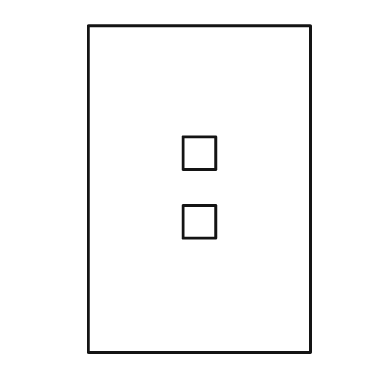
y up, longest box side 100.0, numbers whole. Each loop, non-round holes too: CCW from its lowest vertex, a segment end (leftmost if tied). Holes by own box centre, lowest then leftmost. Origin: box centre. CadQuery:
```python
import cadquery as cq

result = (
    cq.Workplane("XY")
    .moveTo(-34.0, -50.0)
    .lineTo(34.0, -50.0)
    .lineTo(34.0, 50.0)
    .lineTo(-34.0, 50.0)
    .close()
    .moveTo(-5.0, -15.0)
    .lineTo(5.0, -15.0)
    .lineTo(5.0, -5.0)
    .lineTo(-5.0, -5.0)
    .close()
    .moveTo(-5.0, 6.0)
    .lineTo(5.0, 6.0)
    .lineTo(5.0, 16.0)
    .lineTo(-5.0, 16.0)
    .close()
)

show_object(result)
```